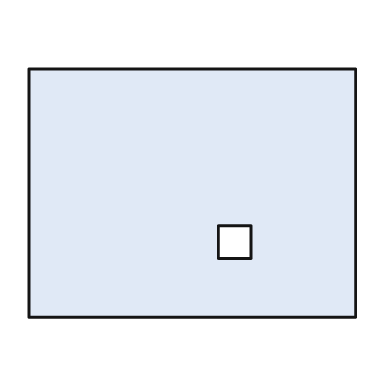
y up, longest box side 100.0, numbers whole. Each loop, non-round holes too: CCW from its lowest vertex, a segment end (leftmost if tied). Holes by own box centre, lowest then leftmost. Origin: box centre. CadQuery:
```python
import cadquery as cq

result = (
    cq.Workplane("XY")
    .moveTo(-50.0, -38.0)
    .lineTo(50.0, -38.0)
    .lineTo(50.0, 38.0)
    .lineTo(-50.0, 38.0)
    .close()
    .moveTo(8.0, -20.0)
    .lineTo(18.0, -20.0)
    .lineTo(18.0, -10.0)
    .lineTo(8.0, -10.0)
    .close()
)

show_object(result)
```